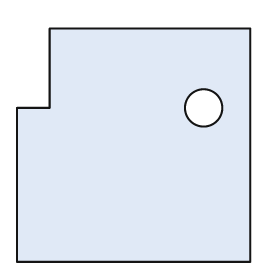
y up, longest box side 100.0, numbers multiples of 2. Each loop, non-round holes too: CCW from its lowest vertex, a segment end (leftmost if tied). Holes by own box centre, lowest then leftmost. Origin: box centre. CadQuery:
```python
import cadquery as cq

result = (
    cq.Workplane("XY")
    .moveTo(-50.0, -50.0)
    .lineTo(50.0, -50.0)
    .lineTo(50.0, 50.0)
    .lineTo(-36.0, 50.0)
    .lineTo(-36.0, 16.0)
    .lineTo(-50.0, 16.0)
    .close()
    .moveTo(30.0, 16.0)
    .circle(8.0)
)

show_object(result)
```